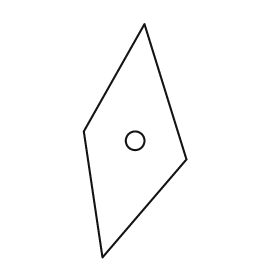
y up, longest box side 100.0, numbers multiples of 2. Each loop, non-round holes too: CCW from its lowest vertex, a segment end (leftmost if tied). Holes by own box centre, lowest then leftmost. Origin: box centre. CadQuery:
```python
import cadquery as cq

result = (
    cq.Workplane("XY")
    .moveTo(-14.0, -50.0)
    .lineTo(22.0, -8.0)
    .lineTo(4.0, 50.0)
    .lineTo(-22.0, 4.0)
    .close()
    .moveTo(0.0, 0.0)
    .circle(4.0)
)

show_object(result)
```